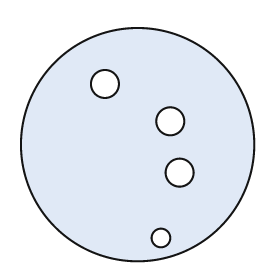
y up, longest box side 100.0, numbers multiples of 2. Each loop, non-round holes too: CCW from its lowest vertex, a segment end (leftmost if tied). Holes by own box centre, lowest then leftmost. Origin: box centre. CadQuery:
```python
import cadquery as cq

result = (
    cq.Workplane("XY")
    .moveTo(0.0, 0.0)
    .circle(50.0)
    .moveTo(10.0, -40.0)
    .circle(4.0)
    .moveTo(18.0, -12.0)
    .circle(6.0)
    .moveTo(14.0, 10.0)
    .circle(6.0)
    .moveTo(-14.0, 26.0)
    .circle(6.0)
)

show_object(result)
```